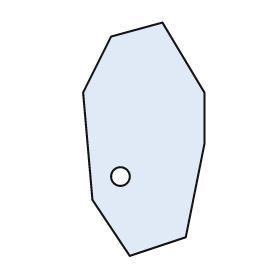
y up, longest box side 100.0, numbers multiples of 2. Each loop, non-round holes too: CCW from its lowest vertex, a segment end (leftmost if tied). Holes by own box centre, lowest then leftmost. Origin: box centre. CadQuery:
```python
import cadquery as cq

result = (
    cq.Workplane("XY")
    .moveTo(-6.0, -50.0)
    .lineTo(18.0, -42.0)
    .lineTo(26.0, -2.0)
    .lineTo(26.0, 20.0)
    .lineTo(8.0, 50.0)
    .lineTo(-14.0, 44.0)
    .lineTo(-26.0, 20.0)
    .lineTo(-22.0, -26.0)
    .close()
    .moveTo(-10.0, -16.0)
    .circle(4.0)
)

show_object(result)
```